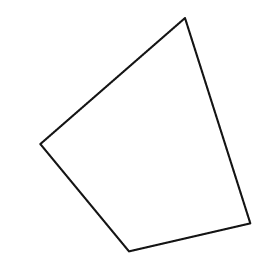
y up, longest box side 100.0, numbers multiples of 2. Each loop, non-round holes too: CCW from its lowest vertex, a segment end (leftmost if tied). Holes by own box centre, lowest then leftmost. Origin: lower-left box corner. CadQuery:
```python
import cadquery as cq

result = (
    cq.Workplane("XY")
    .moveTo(38.0, 0.0)
    .lineTo(90.0, 12.0)
    .lineTo(62.0, 100.0)
    .lineTo(0.0, 46.0)
    .close()
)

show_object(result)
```